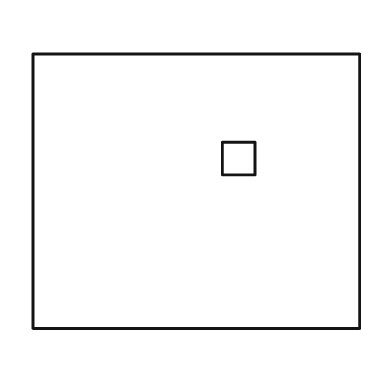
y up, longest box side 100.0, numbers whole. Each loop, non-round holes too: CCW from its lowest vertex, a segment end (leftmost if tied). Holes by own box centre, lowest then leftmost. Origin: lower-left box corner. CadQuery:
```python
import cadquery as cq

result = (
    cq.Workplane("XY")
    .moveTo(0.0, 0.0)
    .lineTo(100.0, 0.0)
    .lineTo(100.0, 84.0)
    .lineTo(0.0, 84.0)
    .close()
    .moveTo(58.0, 47.0)
    .lineTo(68.0, 47.0)
    .lineTo(68.0, 57.0)
    .lineTo(58.0, 57.0)
    .close()
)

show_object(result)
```